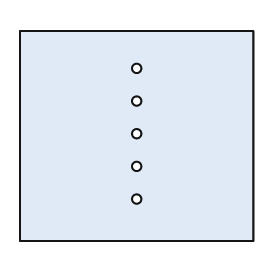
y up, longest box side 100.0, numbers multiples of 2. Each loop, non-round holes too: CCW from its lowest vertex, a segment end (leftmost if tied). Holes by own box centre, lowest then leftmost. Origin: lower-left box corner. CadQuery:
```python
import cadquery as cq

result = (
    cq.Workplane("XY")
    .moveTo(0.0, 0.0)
    .lineTo(100.0, 0.0)
    .lineTo(100.0, 90.0)
    .lineTo(0.0, 90.0)
    .close()
    .moveTo(50.0, 18.0)
    .circle(2.0)
    .moveTo(50.0, 32.0)
    .circle(2.0)
    .moveTo(50.0, 46.0)
    .circle(2.0)
    .moveTo(50.0, 60.0)
    .circle(2.0)
    .moveTo(50.0, 74.0)
    .circle(2.0)
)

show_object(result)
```